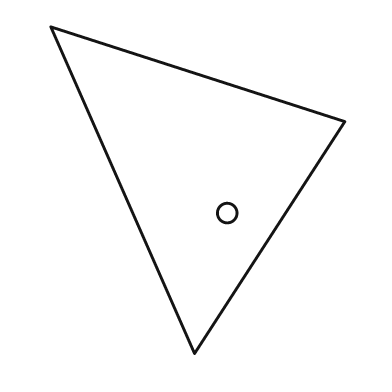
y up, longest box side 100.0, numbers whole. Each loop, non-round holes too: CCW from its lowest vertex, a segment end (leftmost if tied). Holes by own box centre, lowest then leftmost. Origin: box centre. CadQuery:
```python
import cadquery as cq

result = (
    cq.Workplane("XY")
    .moveTo(-1.0, -50.0)
    .lineTo(45.0, 21.0)
    .lineTo(-45.0, 50.0)
    .close()
    .moveTo(9.0, -7.0)
    .circle(3.0)
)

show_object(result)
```